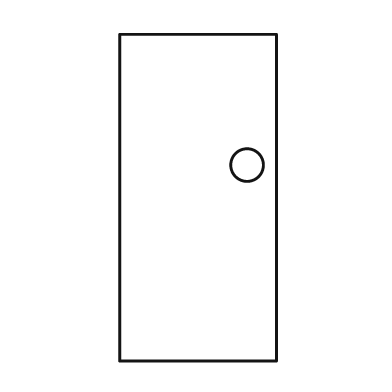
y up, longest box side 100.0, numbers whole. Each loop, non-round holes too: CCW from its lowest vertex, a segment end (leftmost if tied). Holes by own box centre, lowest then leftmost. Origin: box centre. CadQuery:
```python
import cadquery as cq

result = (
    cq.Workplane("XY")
    .moveTo(-24.0, -50.0)
    .lineTo(24.0, -50.0)
    .lineTo(24.0, 50.0)
    .lineTo(-24.0, 50.0)
    .close()
    .moveTo(15.0, 10.0)
    .circle(5.0)
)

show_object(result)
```